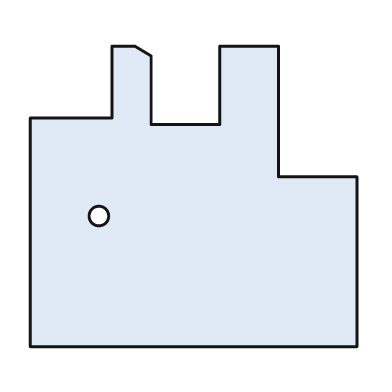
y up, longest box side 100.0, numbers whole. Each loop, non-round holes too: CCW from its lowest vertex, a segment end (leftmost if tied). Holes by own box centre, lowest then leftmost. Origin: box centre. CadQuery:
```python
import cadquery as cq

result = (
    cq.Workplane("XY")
    .moveTo(-50.0, -46.0)
    .lineTo(50.0, -46.0)
    .lineTo(50.0, 6.0)
    .lineTo(26.0, 6.0)
    .lineTo(26.0, 46.0)
    .lineTo(8.0, 46.0)
    .lineTo(8.0, 22.0)
    .lineTo(-13.0, 22.0)
    .lineTo(-13.0, 43.0)
    .lineTo(-18.0, 46.0)
    .lineTo(-25.0, 46.0)
    .lineTo(-25.0, 24.0)
    .lineTo(-50.0, 24.0)
    .close()
    .moveTo(-29.0, -6.0)
    .circle(3.0)
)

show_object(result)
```